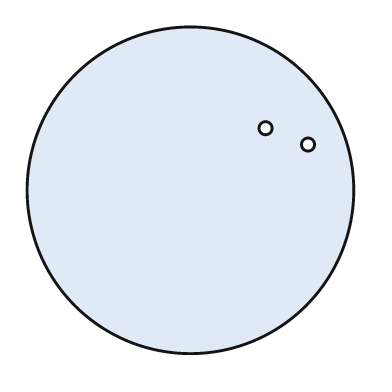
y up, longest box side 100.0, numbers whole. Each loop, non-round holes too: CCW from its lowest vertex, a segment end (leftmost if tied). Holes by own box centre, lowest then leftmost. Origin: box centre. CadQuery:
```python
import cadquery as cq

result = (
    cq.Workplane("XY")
    .moveTo(0.0, 0.0)
    .circle(50.0)
    .moveTo(36.0, 14.0)
    .circle(2.0)
    .moveTo(23.0, 19.0)
    .circle(2.0)
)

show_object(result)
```